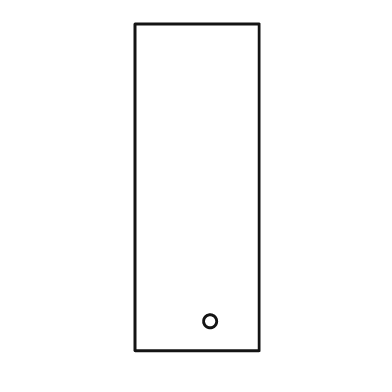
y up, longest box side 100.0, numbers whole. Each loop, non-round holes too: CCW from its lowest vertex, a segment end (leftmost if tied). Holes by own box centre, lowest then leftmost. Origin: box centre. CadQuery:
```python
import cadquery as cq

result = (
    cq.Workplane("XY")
    .moveTo(-19.0, -50.0)
    .lineTo(19.0, -50.0)
    .lineTo(19.0, 50.0)
    .lineTo(-19.0, 50.0)
    .close()
    .moveTo(4.0, -41.0)
    .circle(2.0)
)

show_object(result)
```